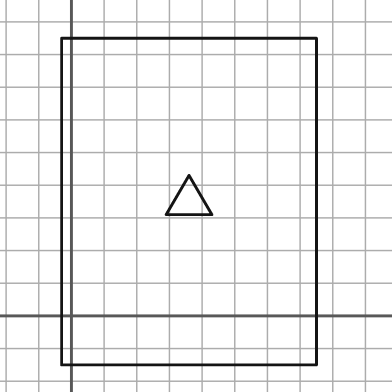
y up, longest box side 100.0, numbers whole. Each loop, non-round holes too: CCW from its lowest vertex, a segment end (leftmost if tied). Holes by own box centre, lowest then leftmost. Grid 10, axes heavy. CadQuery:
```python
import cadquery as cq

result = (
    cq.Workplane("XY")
    .moveTo(-3.0, -15.0)
    .lineTo(75.0, -15.0)
    .lineTo(75.0, 85.0)
    .lineTo(-3.0, 85.0)
    .close()
    .moveTo(29.0, 31.0)
    .lineTo(43.0, 31.0)
    .lineTo(36.0, 43.0)
    .close()
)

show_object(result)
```